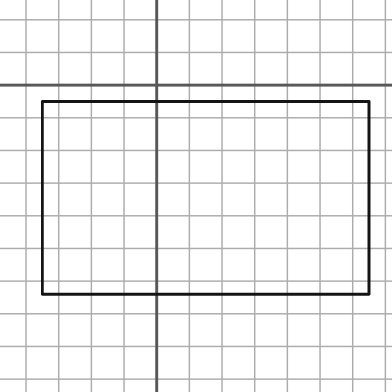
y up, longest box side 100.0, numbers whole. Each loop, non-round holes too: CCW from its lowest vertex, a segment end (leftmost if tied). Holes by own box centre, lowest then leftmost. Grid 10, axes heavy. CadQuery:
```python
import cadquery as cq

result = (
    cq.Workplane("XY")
    .moveTo(-35.0, -64.0)
    .lineTo(65.0, -64.0)
    .lineTo(65.0, -5.0)
    .lineTo(-35.0, -5.0)
    .close()
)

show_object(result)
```